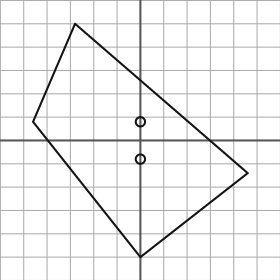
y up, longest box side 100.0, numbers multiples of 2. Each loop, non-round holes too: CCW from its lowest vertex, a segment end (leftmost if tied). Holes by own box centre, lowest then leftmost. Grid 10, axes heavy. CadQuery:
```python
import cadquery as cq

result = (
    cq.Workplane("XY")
    .moveTo(0.0, -50.0)
    .lineTo(46.0, -14.0)
    .lineTo(-28.0, 50.0)
    .lineTo(-46.0, 8.0)
    .close()
    .moveTo(0.0, -8.0)
    .circle(2.0)
    .moveTo(0.0, 8.0)
    .circle(2.0)
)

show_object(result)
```